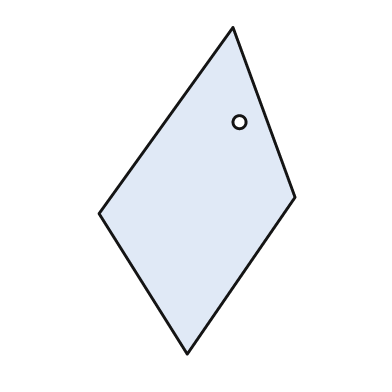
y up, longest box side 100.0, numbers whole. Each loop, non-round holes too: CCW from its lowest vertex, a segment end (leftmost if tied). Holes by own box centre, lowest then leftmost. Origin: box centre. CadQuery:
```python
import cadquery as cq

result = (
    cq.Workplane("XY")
    .moveTo(-3.0, -50.0)
    .lineTo(30.0, -2.0)
    .lineTo(11.0, 50.0)
    .lineTo(-30.0, -7.0)
    .close()
    .moveTo(13.0, 21.0)
    .circle(2.0)
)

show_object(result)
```